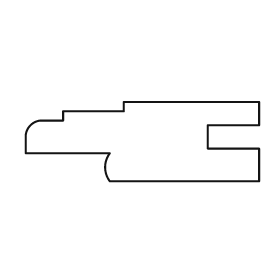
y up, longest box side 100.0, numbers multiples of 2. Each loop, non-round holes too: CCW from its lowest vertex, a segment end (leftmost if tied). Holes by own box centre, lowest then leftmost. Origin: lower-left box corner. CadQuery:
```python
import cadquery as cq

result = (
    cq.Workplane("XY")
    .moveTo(36.0, 0.0)
    .lineTo(100.0, 0.0)
    .lineTo(100.0, 14.0)
    .lineTo(78.0, 14.0)
    .lineTo(78.0, 24.0)
    .lineTo(100.0, 24.0)
    .lineTo(100.0, 34.0)
    .lineTo(42.0, 34.0)
    .lineTo(42.0, 30.0)
    .lineTo(16.0, 30.0)
    .lineTo(16.0, 26.0)
    .lineTo(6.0, 26.0)
    .threePointArc((2.0, 24.0), (0.0, 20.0))
    .lineTo(0.0, 12.0)
    .lineTo(36.0, 12.0)
    .threePointArc((34.0, 6.0), (36.0, 0.0))
    .close()
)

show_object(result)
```